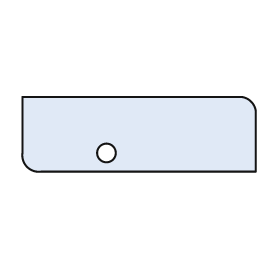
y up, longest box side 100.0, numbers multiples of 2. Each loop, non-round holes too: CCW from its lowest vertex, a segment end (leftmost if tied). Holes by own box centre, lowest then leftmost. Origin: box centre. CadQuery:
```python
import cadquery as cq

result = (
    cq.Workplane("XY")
    .moveTo(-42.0, -16.0)
    .lineTo(50.0, -16.0)
    .lineTo(50.0, 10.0)
    .threePointArc((48.0, 14.0), (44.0, 16.0))
    .lineTo(-50.0, 16.0)
    .lineTo(-50.0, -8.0)
    .threePointArc((-48.0, -14.0), (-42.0, -16.0))
    .close()
    .moveTo(-14.0, -8.0)
    .circle(4.0)
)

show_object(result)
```